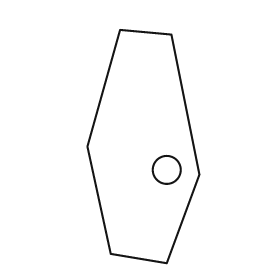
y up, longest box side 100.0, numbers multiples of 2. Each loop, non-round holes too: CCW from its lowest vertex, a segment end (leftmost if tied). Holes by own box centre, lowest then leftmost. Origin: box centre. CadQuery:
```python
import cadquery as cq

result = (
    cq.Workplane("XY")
    .moveTo(10.0, -50.0)
    .lineTo(24.0, -12.0)
    .lineTo(12.0, 48.0)
    .lineTo(-10.0, 50.0)
    .lineTo(-24.0, 0.0)
    .lineTo(-14.0, -46.0)
    .close()
    .moveTo(10.0, -10.0)
    .circle(6.0)
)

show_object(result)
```